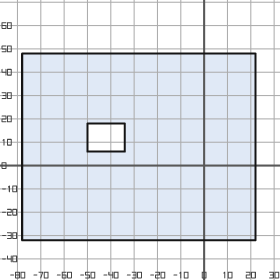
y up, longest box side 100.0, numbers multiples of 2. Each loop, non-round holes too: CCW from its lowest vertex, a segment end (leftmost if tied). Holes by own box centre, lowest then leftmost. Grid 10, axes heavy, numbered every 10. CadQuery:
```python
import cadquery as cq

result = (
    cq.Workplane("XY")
    .moveTo(-78.0, -32.0)
    .lineTo(22.0, -32.0)
    .lineTo(22.0, 48.0)
    .lineTo(-78.0, 48.0)
    .close()
    .moveTo(-50.0, 6.0)
    .lineTo(-34.0, 6.0)
    .lineTo(-34.0, 18.0)
    .lineTo(-50.0, 18.0)
    .close()
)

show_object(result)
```